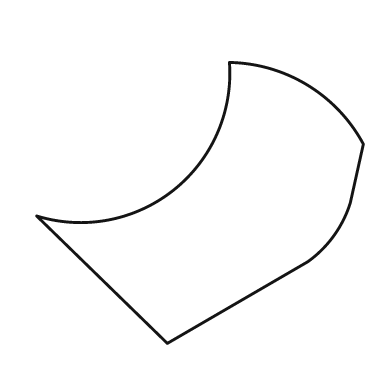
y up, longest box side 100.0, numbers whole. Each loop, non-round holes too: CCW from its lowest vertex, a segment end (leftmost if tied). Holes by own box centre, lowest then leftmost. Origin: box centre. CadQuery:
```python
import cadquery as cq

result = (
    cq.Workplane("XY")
    .moveTo(-10.0, -43.0)
    .lineTo(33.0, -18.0)
    .threePointArc((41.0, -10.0), (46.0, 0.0))
    .lineTo(50.0, 18.0)
    .threePointArc((33.0, 36.0), (9.0, 43.0))
    .threePointArc((-8.0, 4.0), (-50.0, -4.0))
    .close()
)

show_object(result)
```